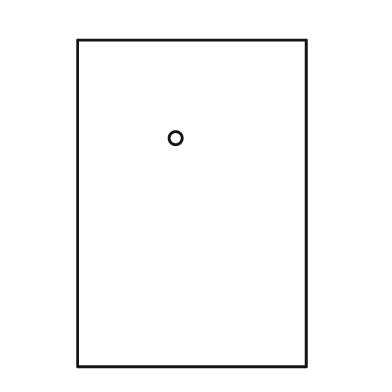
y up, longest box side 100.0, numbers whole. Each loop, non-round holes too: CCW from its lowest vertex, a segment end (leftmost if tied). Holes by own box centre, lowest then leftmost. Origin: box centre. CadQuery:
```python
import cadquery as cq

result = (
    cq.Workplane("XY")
    .moveTo(-35.0, -50.0)
    .lineTo(35.0, -50.0)
    .lineTo(35.0, 50.0)
    .lineTo(-35.0, 50.0)
    .close()
    .moveTo(-5.0, 20.0)
    .circle(2.0)
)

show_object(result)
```